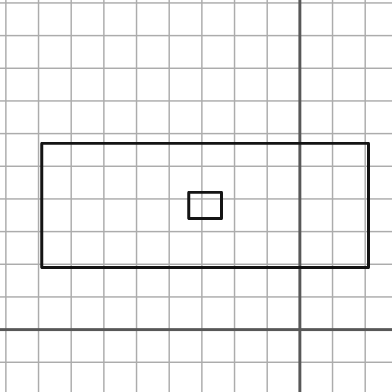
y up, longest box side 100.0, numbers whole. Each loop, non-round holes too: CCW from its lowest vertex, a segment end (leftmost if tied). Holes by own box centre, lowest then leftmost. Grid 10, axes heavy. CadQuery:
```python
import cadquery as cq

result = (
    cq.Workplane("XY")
    .moveTo(-79.0, 19.0)
    .lineTo(21.0, 19.0)
    .lineTo(21.0, 57.0)
    .lineTo(-79.0, 57.0)
    .close()
    .moveTo(-34.0, 34.0)
    .lineTo(-24.0, 34.0)
    .lineTo(-24.0, 42.0)
    .lineTo(-34.0, 42.0)
    .close()
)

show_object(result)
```